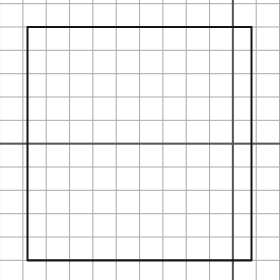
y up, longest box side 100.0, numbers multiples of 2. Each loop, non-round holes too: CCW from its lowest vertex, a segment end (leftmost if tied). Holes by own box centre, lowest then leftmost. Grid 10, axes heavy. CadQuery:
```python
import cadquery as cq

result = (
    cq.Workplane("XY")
    .moveTo(-88.0, -50.0)
    .lineTo(8.0, -50.0)
    .lineTo(8.0, 50.0)
    .lineTo(-88.0, 50.0)
    .close()
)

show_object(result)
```